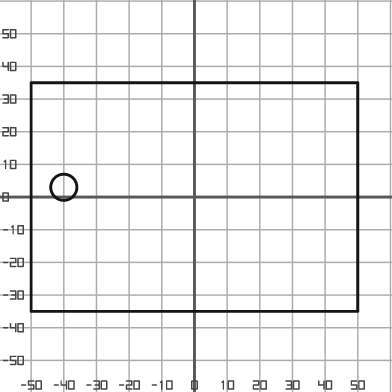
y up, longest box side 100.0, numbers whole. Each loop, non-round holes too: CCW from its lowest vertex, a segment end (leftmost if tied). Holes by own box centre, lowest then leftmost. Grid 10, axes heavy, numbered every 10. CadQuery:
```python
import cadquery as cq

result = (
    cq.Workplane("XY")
    .moveTo(-50.0, -35.0)
    .lineTo(50.0, -35.0)
    .lineTo(50.0, 35.0)
    .lineTo(-50.0, 35.0)
    .close()
    .moveTo(-40.0, 3.0)
    .circle(4.0)
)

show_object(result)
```